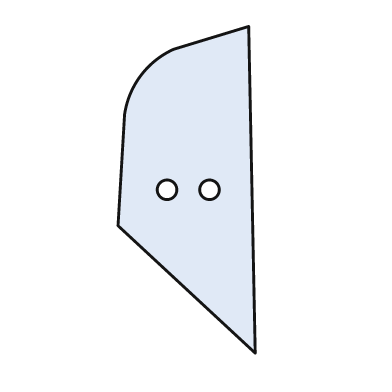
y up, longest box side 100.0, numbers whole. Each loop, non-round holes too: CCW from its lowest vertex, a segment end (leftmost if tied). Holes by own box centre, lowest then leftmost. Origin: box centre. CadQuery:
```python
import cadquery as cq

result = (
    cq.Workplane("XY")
    .moveTo(21.0, -50.0)
    .lineTo(19.0, 50.0)
    .lineTo(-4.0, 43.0)
    .threePointArc((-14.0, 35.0), (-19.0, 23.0))
    .lineTo(-21.0, -11.0)
    .close()
    .moveTo(-6.0, 0.0)
    .circle(3.0)
    .moveTo(7.0, 0.0)
    .circle(3.0)
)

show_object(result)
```